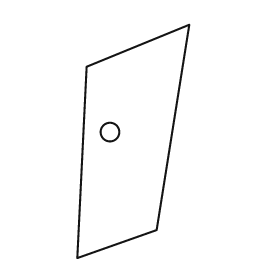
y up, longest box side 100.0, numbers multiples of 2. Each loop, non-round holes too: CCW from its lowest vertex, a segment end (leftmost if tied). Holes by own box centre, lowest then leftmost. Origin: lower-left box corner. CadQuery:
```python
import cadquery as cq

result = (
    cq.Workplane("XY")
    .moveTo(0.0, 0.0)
    .lineTo(34.0, 12.0)
    .lineTo(48.0, 100.0)
    .lineTo(4.0, 82.0)
    .close()
    .moveTo(14.0, 54.0)
    .circle(4.0)
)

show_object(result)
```